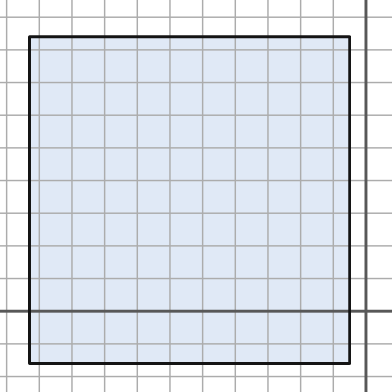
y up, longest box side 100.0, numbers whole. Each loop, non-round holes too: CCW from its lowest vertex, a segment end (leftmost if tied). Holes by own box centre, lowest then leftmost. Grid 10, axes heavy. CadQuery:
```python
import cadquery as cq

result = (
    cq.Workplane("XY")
    .moveTo(-103.0, -16.0)
    .lineTo(-5.0, -16.0)
    .lineTo(-5.0, 84.0)
    .lineTo(-103.0, 84.0)
    .close()
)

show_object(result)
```